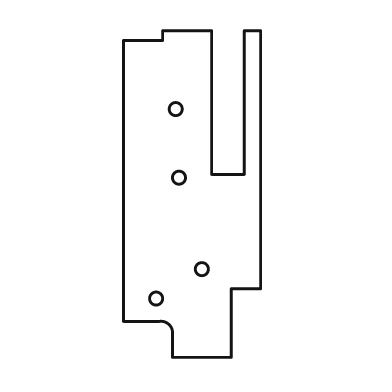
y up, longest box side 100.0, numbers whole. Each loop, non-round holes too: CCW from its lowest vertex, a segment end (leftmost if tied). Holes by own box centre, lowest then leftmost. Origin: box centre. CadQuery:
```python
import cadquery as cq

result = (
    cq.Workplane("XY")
    .moveTo(-6.0, -50.0)
    .lineTo(12.0, -50.0)
    .lineTo(12.0, -29.0)
    .lineTo(21.0, -29.0)
    .lineTo(21.0, 50.0)
    .lineTo(16.0, 50.0)
    .lineTo(16.0, 6.0)
    .lineTo(6.0, 6.0)
    .lineTo(6.0, 50.0)
    .lineTo(-9.0, 50.0)
    .lineTo(-9.0, 47.0)
    .lineTo(-21.0, 47.0)
    .lineTo(-21.0, -39.0)
    .lineTo(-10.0, -39.0)
    .threePointArc((-7.0, -40.0), (-6.0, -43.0))
    .close()
    .moveTo(-11.0, -32.0)
    .circle(2.0)
    .moveTo(3.0, -23.0)
    .circle(2.0)
    .moveTo(-4.0, 5.0)
    .circle(2.0)
    .moveTo(-5.0, 26.0)
    .circle(2.0)
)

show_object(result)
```